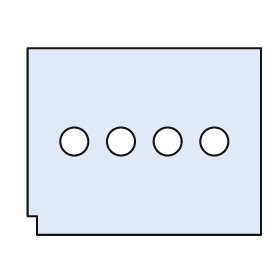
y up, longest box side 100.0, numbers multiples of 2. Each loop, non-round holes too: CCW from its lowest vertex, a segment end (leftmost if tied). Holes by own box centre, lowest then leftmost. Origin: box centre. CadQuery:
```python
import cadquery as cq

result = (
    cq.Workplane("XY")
    .moveTo(-46.0, -40.0)
    .lineTo(50.0, -40.0)
    .lineTo(50.0, 40.0)
    .lineTo(-50.0, 40.0)
    .lineTo(-50.0, -32.0)
    .lineTo(-46.0, -32.0)
    .close()
    .moveTo(-30.0, 0.0)
    .circle(6.0)
    .moveTo(-10.0, 0.0)
    .circle(6.0)
    .moveTo(10.0, 0.0)
    .circle(6.0)
    .moveTo(30.0, 0.0)
    .circle(6.0)
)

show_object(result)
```